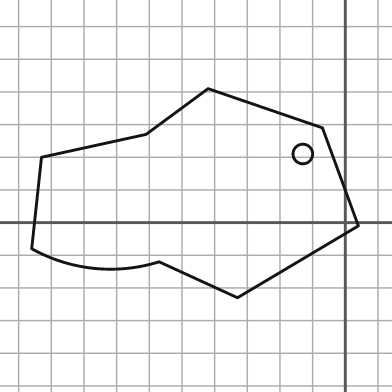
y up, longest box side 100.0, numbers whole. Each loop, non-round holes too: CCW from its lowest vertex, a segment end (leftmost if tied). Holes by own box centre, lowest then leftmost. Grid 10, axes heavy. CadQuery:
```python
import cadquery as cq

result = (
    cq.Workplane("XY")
    .moveTo(-33.0, -23.0)
    .lineTo(4.0, -1.0)
    .lineTo(-7.0, 29.0)
    .lineTo(-42.0, 41.0)
    .lineTo(-61.0, 27.0)
    .lineTo(-93.0, 20.0)
    .lineTo(-96.0, -8.0)
    .threePointArc((-77.0, -14.0), (-57.0, -12.0))
    .close()
    .moveTo(-13.0, 21.0)
    .circle(3.0)
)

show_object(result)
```